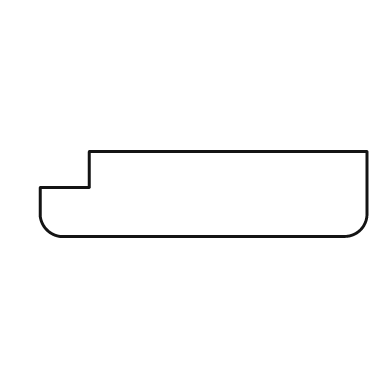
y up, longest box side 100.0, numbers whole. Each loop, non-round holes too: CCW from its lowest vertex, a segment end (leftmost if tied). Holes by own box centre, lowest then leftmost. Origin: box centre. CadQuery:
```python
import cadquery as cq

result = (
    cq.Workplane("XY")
    .moveTo(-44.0, -13.0)
    .lineTo(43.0, -13.0)
    .threePointArc((48.0, -11.0), (50.0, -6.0))
    .lineTo(50.0, 13.0)
    .lineTo(-35.0, 13.0)
    .lineTo(-35.0, 2.0)
    .lineTo(-50.0, 2.0)
    .lineTo(-50.0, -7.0)
    .threePointArc((-48.0, -11.0), (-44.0, -13.0))
    .close()
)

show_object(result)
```